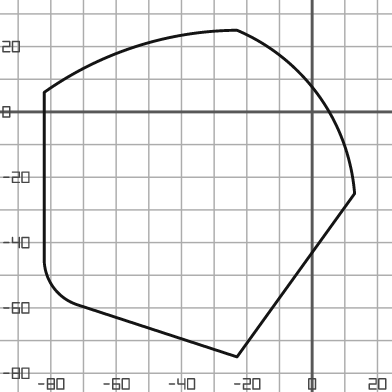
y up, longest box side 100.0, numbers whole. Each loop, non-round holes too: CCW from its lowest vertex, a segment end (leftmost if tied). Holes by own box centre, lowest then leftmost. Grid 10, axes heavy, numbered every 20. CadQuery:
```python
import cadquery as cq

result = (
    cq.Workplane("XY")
    .moveTo(-23.0, -75.0)
    .lineTo(13.0, -25.0)
    .threePointArc((2.0, 5.0), (-23.0, 25.0))
    .threePointArc((-54.0, 20.0), (-82.0, 6.0))
    .lineTo(-82.0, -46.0)
    .threePointArc((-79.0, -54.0), (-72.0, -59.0))
    .close()
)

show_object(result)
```